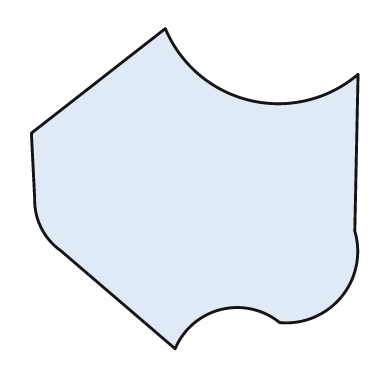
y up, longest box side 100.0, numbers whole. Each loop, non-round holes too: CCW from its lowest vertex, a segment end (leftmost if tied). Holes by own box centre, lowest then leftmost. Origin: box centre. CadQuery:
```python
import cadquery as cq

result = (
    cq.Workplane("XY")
    .moveTo(-6.0, -49.0)
    .threePointArc((8.0, -37.0), (26.0, -41.0))
    .threePointArc((45.0, -33.0), (49.0, -13.0))
    .lineTo(50.0, 35.0)
    .threePointArc((17.0, 27.0), (-9.0, 49.0))
    .lineTo(-50.0, 17.0)
    .lineTo(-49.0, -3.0)
    .threePointArc((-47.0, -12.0), (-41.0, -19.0))
    .close()
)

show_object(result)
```